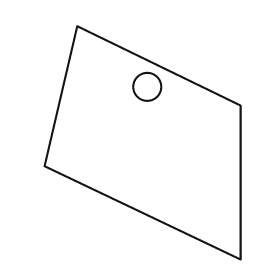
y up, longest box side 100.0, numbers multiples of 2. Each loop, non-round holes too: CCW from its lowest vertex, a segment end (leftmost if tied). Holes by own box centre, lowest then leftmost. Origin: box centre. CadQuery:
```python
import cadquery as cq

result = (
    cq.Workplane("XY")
    .moveTo(42.0, -50.0)
    .lineTo(42.0, 16.0)
    .lineTo(-28.0, 50.0)
    .lineTo(-42.0, -10.0)
    .close()
    .moveTo(2.0, 24.0)
    .circle(6.0)
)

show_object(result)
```